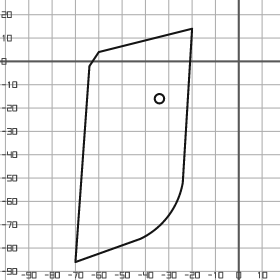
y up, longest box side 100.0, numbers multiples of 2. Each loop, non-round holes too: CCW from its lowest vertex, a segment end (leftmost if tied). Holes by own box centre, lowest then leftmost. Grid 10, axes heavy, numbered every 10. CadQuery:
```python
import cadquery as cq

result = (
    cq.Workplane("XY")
    .moveTo(-70.0, -86.0)
    .lineTo(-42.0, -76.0)
    .threePointArc((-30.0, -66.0), (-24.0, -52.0))
    .lineTo(-20.0, 14.0)
    .lineTo(-60.0, 4.0)
    .lineTo(-64.0, -2.0)
    .close()
    .moveTo(-34.0, -16.0)
    .circle(2.0)
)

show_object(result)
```